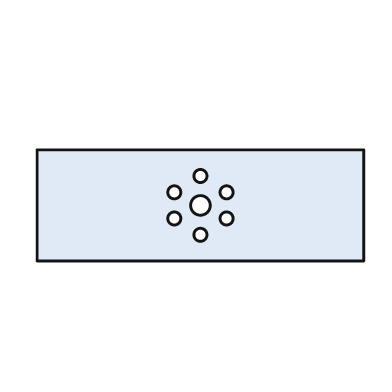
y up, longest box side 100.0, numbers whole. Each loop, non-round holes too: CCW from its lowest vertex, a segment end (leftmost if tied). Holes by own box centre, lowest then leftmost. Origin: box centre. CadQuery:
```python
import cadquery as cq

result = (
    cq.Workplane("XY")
    .moveTo(-50.0, -17.0)
    .lineTo(50.0, -17.0)
    .lineTo(50.0, 17.0)
    .lineTo(-50.0, 17.0)
    .close()
    .moveTo(0.0, -9.0)
    .circle(2.0)
    .moveTo(-8.0, -4.0)
    .circle(2.0)
    .moveTo(8.0, -4.0)
    .circle(2.0)
    .moveTo(0.0, 0.0)
    .circle(3.0)
    .moveTo(-8.0, 4.0)
    .circle(2.0)
    .moveTo(8.0, 4.0)
    .circle(2.0)
    .moveTo(0.0, 9.0)
    .circle(2.0)
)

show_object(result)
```